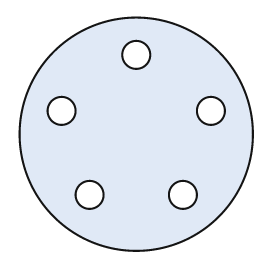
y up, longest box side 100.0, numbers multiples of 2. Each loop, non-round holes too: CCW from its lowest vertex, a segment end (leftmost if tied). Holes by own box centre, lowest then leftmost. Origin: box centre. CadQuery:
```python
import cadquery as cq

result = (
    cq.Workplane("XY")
    .moveTo(0.0, 0.0)
    .circle(50.0)
    .moveTo(-20.0, -26.0)
    .circle(6.0)
    .moveTo(20.0, -26.0)
    .circle(6.0)
    .moveTo(-32.0, 10.0)
    .circle(6.0)
    .moveTo(32.0, 10.0)
    .circle(6.0)
    .moveTo(0.0, 34.0)
    .circle(6.0)
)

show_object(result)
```